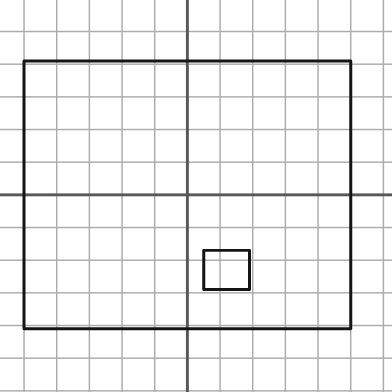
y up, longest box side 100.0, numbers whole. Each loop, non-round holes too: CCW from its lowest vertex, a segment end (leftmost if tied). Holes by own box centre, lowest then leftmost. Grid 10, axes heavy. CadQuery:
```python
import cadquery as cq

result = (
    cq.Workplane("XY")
    .moveTo(-50.0, -41.0)
    .lineTo(50.0, -41.0)
    .lineTo(50.0, 41.0)
    .lineTo(-50.0, 41.0)
    .close()
    .moveTo(5.0, -29.0)
    .lineTo(19.0, -29.0)
    .lineTo(19.0, -17.0)
    .lineTo(5.0, -17.0)
    .close()
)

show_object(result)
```